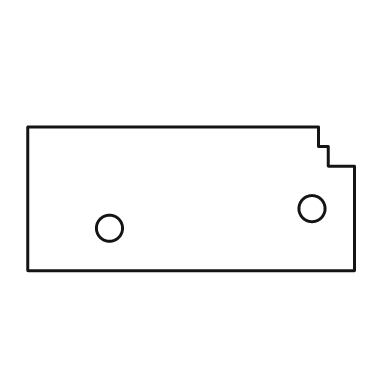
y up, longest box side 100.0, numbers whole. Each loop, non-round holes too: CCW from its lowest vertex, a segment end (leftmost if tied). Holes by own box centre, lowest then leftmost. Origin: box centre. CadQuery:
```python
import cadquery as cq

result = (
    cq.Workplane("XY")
    .moveTo(-50.0, -22.0)
    .lineTo(50.0, -22.0)
    .lineTo(50.0, 10.0)
    .lineTo(42.0, 10.0)
    .lineTo(42.0, 16.0)
    .lineTo(39.0, 16.0)
    .lineTo(39.0, 22.0)
    .lineTo(-50.0, 22.0)
    .close()
    .moveTo(-25.0, -9.0)
    .circle(4.0)
    .moveTo(37.0, -3.0)
    .circle(4.0)
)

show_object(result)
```